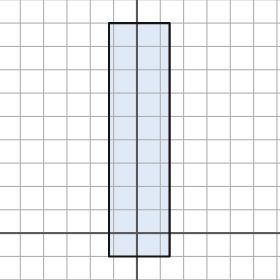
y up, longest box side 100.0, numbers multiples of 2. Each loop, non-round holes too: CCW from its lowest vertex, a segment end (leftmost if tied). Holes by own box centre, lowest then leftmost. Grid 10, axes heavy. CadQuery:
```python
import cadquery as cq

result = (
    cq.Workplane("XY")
    .moveTo(-12.0, -10.0)
    .lineTo(14.0, -10.0)
    .lineTo(14.0, 90.0)
    .lineTo(-12.0, 90.0)
    .close()
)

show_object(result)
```